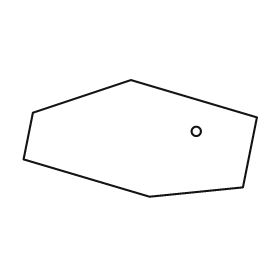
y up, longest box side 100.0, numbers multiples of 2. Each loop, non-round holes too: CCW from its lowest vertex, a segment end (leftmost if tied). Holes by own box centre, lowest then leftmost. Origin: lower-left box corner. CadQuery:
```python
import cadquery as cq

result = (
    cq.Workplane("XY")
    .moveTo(54.0, 0.0)
    .lineTo(94.0, 4.0)
    .lineTo(100.0, 34.0)
    .lineTo(46.0, 50.0)
    .lineTo(4.0, 36.0)
    .lineTo(0.0, 16.0)
    .close()
    .moveTo(74.0, 28.0)
    .circle(2.0)
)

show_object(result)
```